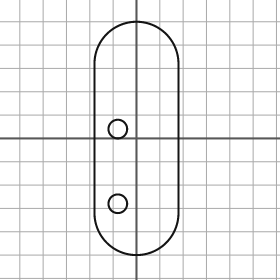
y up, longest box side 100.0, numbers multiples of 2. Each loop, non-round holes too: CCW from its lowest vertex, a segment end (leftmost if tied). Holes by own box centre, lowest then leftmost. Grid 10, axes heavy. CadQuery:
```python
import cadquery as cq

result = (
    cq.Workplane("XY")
    .moveTo(-18.0, -32.0)
    .threePointArc((0.0, -50.0), (18.0, -32.0))
    .lineTo(18.0, 32.0)
    .threePointArc((0.0, 50.0), (-18.0, 32.0))
    .close()
    .moveTo(-8.0, -28.0)
    .circle(4.0)
    .moveTo(-8.0, 4.0)
    .circle(4.0)
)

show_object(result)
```